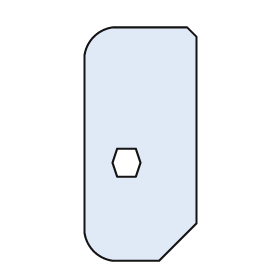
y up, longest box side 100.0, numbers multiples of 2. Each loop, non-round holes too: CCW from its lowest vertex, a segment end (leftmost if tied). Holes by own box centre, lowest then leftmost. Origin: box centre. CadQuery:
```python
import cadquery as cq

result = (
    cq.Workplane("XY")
    .moveTo(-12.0, -50.0)
    .lineTo(8.0, -50.0)
    .lineTo(24.0, -34.0)
    .lineTo(24.0, 46.0)
    .lineTo(20.0, 50.0)
    .lineTo(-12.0, 50.0)
    .threePointArc((-20.0, 46.0), (-24.0, 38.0))
    .lineTo(-24.0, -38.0)
    .threePointArc((-20.0, -46.0), (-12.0, -50.0))
    .close()
    .moveTo(-10.0, -14.0)
    .lineTo(-2.0, -14.0)
    .lineTo(0.0, -8.0)
    .lineTo(-2.0, -2.0)
    .lineTo(-10.0, -2.0)
    .lineTo(-12.0, -8.0)
    .close()
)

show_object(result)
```